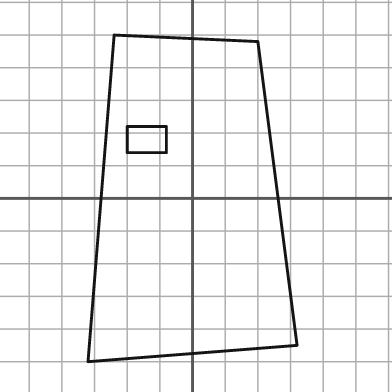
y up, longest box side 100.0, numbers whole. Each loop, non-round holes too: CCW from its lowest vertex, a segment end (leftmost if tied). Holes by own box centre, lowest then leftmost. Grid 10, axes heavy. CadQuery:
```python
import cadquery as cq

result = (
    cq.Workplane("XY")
    .moveTo(-32.0, -50.0)
    .lineTo(32.0, -45.0)
    .lineTo(20.0, 48.0)
    .lineTo(-24.0, 50.0)
    .close()
    .moveTo(-20.0, 14.0)
    .lineTo(-8.0, 14.0)
    .lineTo(-8.0, 22.0)
    .lineTo(-20.0, 22.0)
    .close()
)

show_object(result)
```